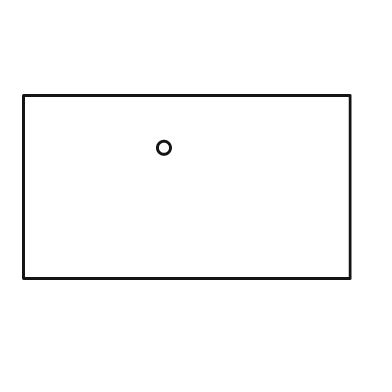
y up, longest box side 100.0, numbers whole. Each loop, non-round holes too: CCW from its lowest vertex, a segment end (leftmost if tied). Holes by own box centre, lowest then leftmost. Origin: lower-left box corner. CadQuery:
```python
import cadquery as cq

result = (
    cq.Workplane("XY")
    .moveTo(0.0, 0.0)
    .lineTo(100.0, 0.0)
    .lineTo(100.0, 56.0)
    .lineTo(0.0, 56.0)
    .close()
    .moveTo(43.0, 40.0)
    .circle(2.0)
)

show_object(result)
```